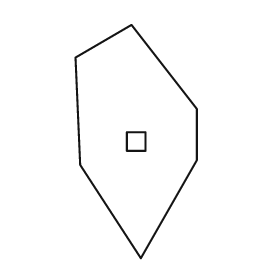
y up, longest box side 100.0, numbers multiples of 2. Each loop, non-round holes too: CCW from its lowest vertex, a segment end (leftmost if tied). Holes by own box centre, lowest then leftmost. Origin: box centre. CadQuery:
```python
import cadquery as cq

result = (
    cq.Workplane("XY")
    .moveTo(2.0, -50.0)
    .lineTo(26.0, -8.0)
    .lineTo(26.0, 14.0)
    .lineTo(-2.0, 50.0)
    .lineTo(-26.0, 36.0)
    .lineTo(-24.0, -10.0)
    .close()
    .moveTo(-4.0, -4.0)
    .lineTo(4.0, -4.0)
    .lineTo(4.0, 4.0)
    .lineTo(-4.0, 4.0)
    .close()
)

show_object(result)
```